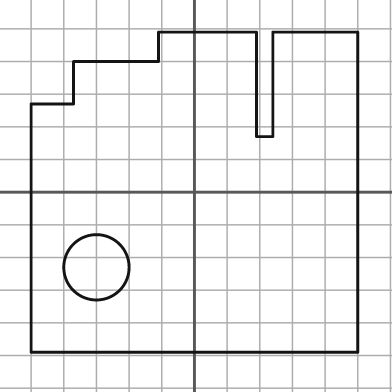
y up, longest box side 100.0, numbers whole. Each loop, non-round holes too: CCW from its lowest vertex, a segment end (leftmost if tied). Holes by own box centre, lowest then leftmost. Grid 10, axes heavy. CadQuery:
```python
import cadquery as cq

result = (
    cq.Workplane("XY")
    .moveTo(-50.0, -49.0)
    .lineTo(50.0, -49.0)
    .lineTo(50.0, 49.0)
    .lineTo(24.0, 49.0)
    .lineTo(24.0, 17.0)
    .lineTo(19.0, 17.0)
    .lineTo(19.0, 49.0)
    .lineTo(-11.0, 49.0)
    .lineTo(-11.0, 40.0)
    .lineTo(-37.0, 40.0)
    .lineTo(-37.0, 27.0)
    .lineTo(-50.0, 27.0)
    .close()
    .moveTo(-30.0, -23.0)
    .circle(10.0)
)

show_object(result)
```